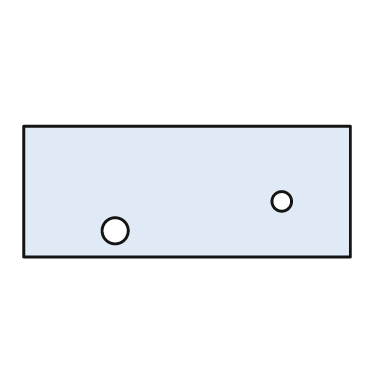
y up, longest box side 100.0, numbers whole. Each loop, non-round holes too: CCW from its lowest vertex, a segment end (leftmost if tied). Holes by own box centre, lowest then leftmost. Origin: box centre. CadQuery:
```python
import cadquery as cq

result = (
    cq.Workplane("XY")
    .moveTo(-50.0, -20.0)
    .lineTo(50.0, -20.0)
    .lineTo(50.0, 20.0)
    .lineTo(-50.0, 20.0)
    .close()
    .moveTo(-22.0, -12.0)
    .circle(4.0)
    .moveTo(29.0, -3.0)
    .circle(3.0)
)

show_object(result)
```